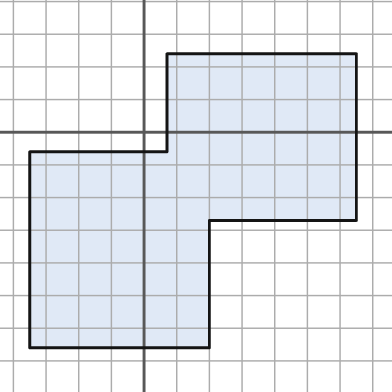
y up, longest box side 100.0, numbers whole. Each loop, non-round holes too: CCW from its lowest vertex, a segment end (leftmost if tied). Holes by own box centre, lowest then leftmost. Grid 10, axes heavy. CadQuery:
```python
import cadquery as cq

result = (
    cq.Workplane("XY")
    .moveTo(-35.0, -66.0)
    .lineTo(20.0, -66.0)
    .lineTo(20.0, -27.0)
    .lineTo(65.0, -27.0)
    .lineTo(65.0, 24.0)
    .lineTo(7.0, 24.0)
    .lineTo(7.0, -6.0)
    .lineTo(-35.0, -6.0)
    .close()
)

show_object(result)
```